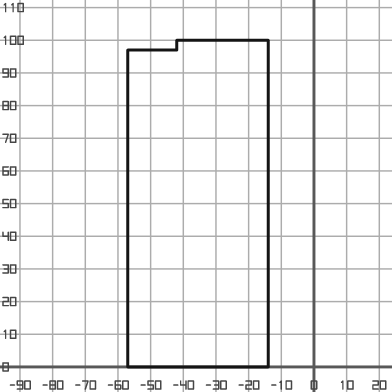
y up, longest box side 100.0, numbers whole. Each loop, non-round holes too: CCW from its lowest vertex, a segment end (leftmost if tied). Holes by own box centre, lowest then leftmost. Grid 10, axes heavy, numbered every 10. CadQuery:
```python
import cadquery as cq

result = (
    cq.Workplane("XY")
    .moveTo(-57.0, 0.0)
    .lineTo(-14.0, 0.0)
    .lineTo(-14.0, 100.0)
    .lineTo(-42.0, 100.0)
    .lineTo(-42.0, 97.0)
    .lineTo(-57.0, 97.0)
    .close()
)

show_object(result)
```